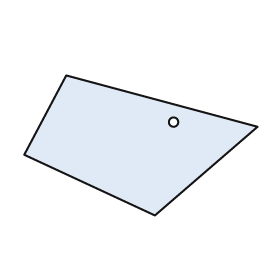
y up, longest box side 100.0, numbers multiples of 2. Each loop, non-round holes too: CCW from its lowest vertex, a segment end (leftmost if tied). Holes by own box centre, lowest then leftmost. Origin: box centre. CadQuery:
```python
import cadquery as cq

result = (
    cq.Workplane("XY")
    .moveTo(6.0, -30.0)
    .lineTo(50.0, 8.0)
    .lineTo(-32.0, 30.0)
    .lineTo(-50.0, -4.0)
    .close()
    .moveTo(14.0, 10.0)
    .circle(2.0)
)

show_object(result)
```